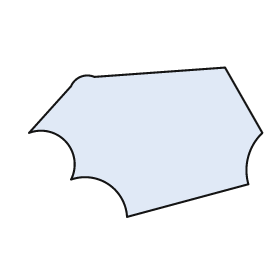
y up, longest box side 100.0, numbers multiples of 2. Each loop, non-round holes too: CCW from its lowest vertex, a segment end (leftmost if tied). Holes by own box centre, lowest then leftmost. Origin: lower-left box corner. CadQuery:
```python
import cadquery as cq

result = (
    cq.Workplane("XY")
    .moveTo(42.0, 0.0)
    .lineTo(94.0, 14.0)
    .threePointArc((94.0, 26.0), (100.0, 36.0))
    .lineTo(84.0, 64.0)
    .lineTo(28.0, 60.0)
    .threePointArc((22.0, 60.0), (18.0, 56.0))
    .lineTo(0.0, 36.0)
    .threePointArc((16.0, 32.0), (18.0, 16.0))
    .threePointArc((34.0, 14.0), (42.0, 0.0))
    .close()
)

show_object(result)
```